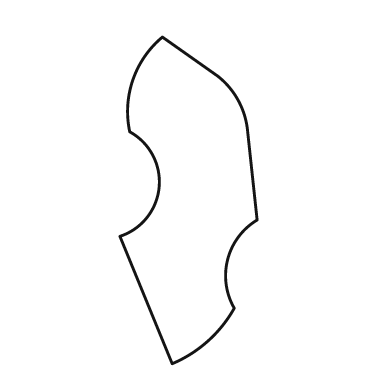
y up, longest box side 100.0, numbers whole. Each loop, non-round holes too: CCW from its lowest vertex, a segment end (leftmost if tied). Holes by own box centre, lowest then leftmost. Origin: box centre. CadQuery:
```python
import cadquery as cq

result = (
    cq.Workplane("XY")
    .moveTo(-5.0, -50.0)
    .threePointArc((6.0, -43.0), (14.0, -33.0))
    .threePointArc((12.0, -18.0), (21.0, -6.0))
    .lineTo(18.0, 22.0)
    .threePointArc((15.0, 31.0), (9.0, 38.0))
    .lineTo(-8.0, 50.0)
    .threePointArc((-17.0, 37.0), (-18.0, 21.0))
    .threePointArc((-9.0, 4.0), (-21.0, -11.0))
    .close()
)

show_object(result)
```